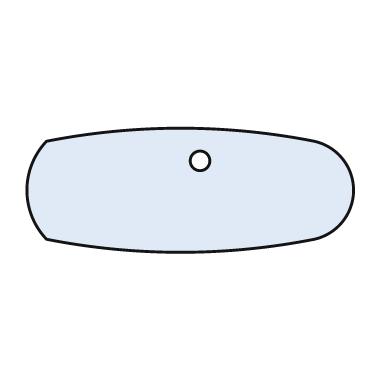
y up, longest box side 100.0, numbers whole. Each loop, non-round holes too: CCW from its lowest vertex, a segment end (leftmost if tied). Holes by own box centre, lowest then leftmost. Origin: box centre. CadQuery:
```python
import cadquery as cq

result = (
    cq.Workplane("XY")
    .moveTo(-44.0, -15.0)
    .threePointArc((-3.0, -19.0), (38.0, -15.0))
    .threePointArc((50.0, 0.0), (38.0, 15.0))
    .threePointArc((-3.0, 19.0), (-44.0, 15.0))
    .threePointArc((-50.0, 0.0), (-44.0, -15.0))
    .close()
    .moveTo(3.0, 9.0)
    .circle(3.0)
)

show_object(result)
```